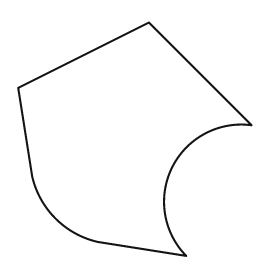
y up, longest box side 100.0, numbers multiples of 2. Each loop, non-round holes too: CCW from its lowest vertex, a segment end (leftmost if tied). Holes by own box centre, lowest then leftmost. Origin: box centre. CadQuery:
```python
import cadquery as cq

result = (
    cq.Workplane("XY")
    .moveTo(22.0, -50.0)
    .threePointArc((16.0, -12.0), (50.0, 6.0))
    .lineTo(6.0, 50.0)
    .lineTo(-50.0, 22.0)
    .lineTo(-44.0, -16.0)
    .threePointArc((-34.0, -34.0), (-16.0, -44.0))
    .close()
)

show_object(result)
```